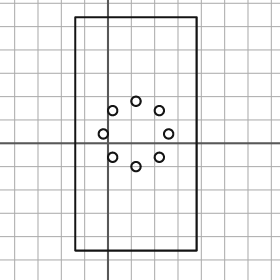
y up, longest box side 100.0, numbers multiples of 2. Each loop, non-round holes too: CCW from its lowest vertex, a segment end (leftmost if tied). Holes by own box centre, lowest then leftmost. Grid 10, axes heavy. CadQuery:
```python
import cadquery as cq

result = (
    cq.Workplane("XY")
    .moveTo(-14.0, -46.0)
    .lineTo(38.0, -46.0)
    .lineTo(38.0, 54.0)
    .lineTo(-14.0, 54.0)
    .close()
    .moveTo(12.0, -10.0)
    .circle(2.0)
    .moveTo(2.0, -6.0)
    .circle(2.0)
    .moveTo(22.0, -6.0)
    .circle(2.0)
    .moveTo(-2.0, 4.0)
    .circle(2.0)
    .moveTo(26.0, 4.0)
    .circle(2.0)
    .moveTo(2.0, 14.0)
    .circle(2.0)
    .moveTo(22.0, 14.0)
    .circle(2.0)
    .moveTo(12.0, 18.0)
    .circle(2.0)
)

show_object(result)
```